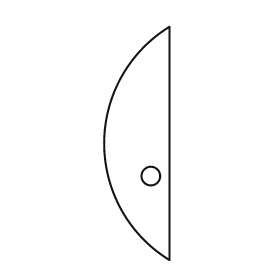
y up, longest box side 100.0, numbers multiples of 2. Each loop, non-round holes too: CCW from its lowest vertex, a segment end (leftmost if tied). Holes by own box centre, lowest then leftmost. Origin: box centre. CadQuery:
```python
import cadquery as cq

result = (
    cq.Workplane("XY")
    .moveTo(14.0, -50.0)
    .lineTo(14.0, 50.0)
    .threePointArc((-14.0, 0.0), (14.0, -50.0))
    .close()
    .moveTo(6.0, -14.0)
    .circle(4.0)
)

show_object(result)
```